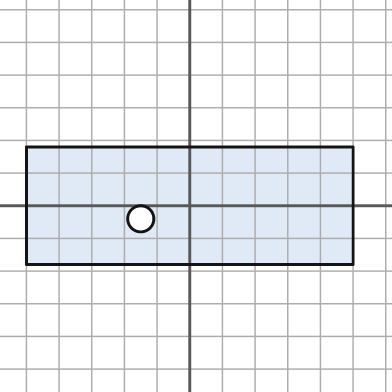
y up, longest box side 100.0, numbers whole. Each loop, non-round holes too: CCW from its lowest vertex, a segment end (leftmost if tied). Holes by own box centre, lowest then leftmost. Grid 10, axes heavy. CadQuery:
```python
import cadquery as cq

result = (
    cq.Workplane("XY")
    .moveTo(-50.0, -18.0)
    .lineTo(50.0, -18.0)
    .lineTo(50.0, 18.0)
    .lineTo(-50.0, 18.0)
    .close()
    .moveTo(-15.0, -4.0)
    .circle(4.0)
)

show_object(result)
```